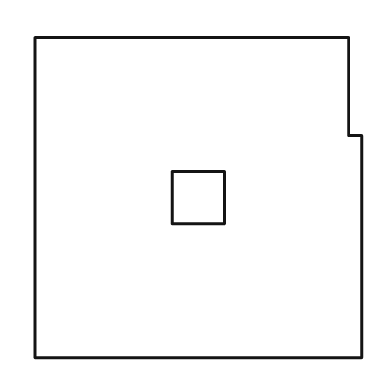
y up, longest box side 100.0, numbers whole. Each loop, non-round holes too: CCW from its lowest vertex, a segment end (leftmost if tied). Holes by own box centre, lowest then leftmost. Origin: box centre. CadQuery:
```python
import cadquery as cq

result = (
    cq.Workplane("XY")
    .moveTo(-50.0, -49.0)
    .lineTo(50.0, -49.0)
    .lineTo(50.0, 19.0)
    .lineTo(46.0, 19.0)
    .lineTo(46.0, 49.0)
    .lineTo(-50.0, 49.0)
    .close()
    .moveTo(-8.0, -8.0)
    .lineTo(8.0, -8.0)
    .lineTo(8.0, 8.0)
    .lineTo(-8.0, 8.0)
    .close()
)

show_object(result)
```